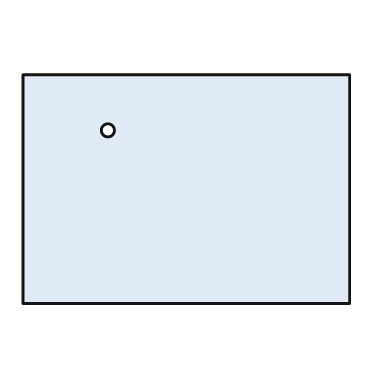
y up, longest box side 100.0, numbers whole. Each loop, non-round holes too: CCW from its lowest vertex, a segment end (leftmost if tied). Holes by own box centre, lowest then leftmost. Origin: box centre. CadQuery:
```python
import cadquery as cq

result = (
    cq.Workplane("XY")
    .moveTo(-50.0, -35.0)
    .lineTo(50.0, -35.0)
    .lineTo(50.0, 35.0)
    .lineTo(-50.0, 35.0)
    .close()
    .moveTo(-24.0, 18.0)
    .circle(2.0)
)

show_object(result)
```